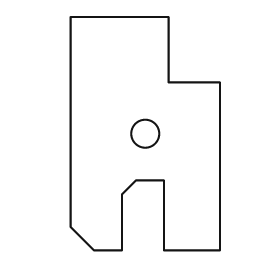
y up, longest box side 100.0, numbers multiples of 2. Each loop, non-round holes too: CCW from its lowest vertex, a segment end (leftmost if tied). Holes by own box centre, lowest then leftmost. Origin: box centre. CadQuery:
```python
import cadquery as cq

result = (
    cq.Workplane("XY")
    .moveTo(-22.0, -50.0)
    .lineTo(-10.0, -50.0)
    .lineTo(-10.0, -26.0)
    .lineTo(-4.0, -20.0)
    .lineTo(8.0, -20.0)
    .lineTo(8.0, -50.0)
    .lineTo(32.0, -50.0)
    .lineTo(32.0, 22.0)
    .lineTo(10.0, 22.0)
    .lineTo(10.0, 50.0)
    .lineTo(-32.0, 50.0)
    .lineTo(-32.0, -40.0)
    .close()
    .moveTo(0.0, 0.0)
    .circle(6.0)
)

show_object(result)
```